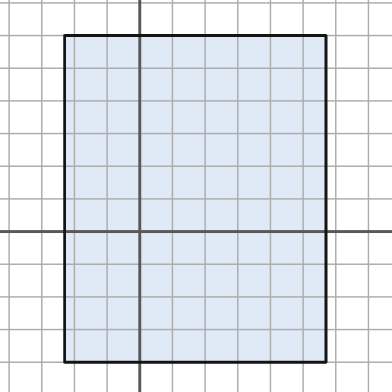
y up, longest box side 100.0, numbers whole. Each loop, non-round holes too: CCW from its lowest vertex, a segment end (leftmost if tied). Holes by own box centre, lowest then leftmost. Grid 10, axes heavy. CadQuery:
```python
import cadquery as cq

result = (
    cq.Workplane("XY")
    .moveTo(-23.0, -40.0)
    .lineTo(57.0, -40.0)
    .lineTo(57.0, 60.0)
    .lineTo(-23.0, 60.0)
    .close()
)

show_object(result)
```